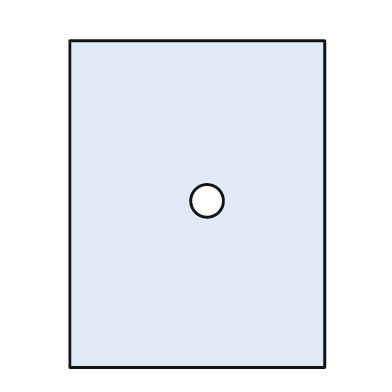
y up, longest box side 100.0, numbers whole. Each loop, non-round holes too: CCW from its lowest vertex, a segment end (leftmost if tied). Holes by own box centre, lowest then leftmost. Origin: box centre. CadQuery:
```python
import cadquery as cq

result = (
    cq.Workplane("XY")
    .moveTo(-39.0, -50.0)
    .lineTo(39.0, -50.0)
    .lineTo(39.0, 50.0)
    .lineTo(-39.0, 50.0)
    .close()
    .moveTo(3.0, 1.0)
    .circle(5.0)
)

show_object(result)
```